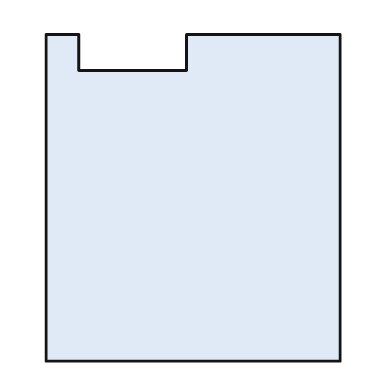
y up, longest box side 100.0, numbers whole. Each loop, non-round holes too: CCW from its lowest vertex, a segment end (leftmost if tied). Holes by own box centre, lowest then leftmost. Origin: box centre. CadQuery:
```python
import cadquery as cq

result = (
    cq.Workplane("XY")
    .moveTo(-45.0, -50.0)
    .lineTo(45.0, -50.0)
    .lineTo(45.0, 50.0)
    .lineTo(-2.0, 50.0)
    .lineTo(-2.0, 39.0)
    .lineTo(-35.0, 39.0)
    .lineTo(-35.0, 50.0)
    .lineTo(-45.0, 50.0)
    .close()
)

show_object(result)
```